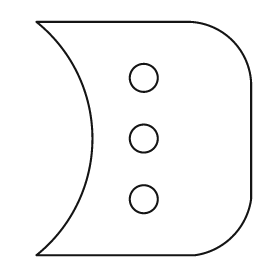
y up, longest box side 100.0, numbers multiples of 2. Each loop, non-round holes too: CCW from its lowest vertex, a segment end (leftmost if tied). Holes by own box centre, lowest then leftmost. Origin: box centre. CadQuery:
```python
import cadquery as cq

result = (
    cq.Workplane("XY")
    .moveTo(-46.0, -50.0)
    .lineTo(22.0, -50.0)
    .threePointArc((38.0, -42.0), (46.0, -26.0))
    .lineTo(46.0, 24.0)
    .threePointArc((38.0, 42.0), (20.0, 50.0))
    .lineTo(-46.0, 50.0)
    .threePointArc((-22.0, 0.0), (-46.0, -50.0))
    .close()
    .moveTo(0.0, -26.0)
    .circle(6.0)
    .moveTo(0.0, 0.0)
    .circle(6.0)
    .moveTo(0.0, 26.0)
    .circle(6.0)
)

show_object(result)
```